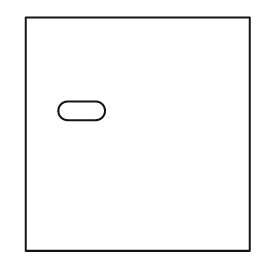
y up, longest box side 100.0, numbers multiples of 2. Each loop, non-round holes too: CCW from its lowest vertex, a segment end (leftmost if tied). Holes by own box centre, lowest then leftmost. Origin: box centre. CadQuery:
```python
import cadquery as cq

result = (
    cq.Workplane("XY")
    .moveTo(-48.0, -50.0)
    .lineTo(48.0, -50.0)
    .lineTo(48.0, 50.0)
    .lineTo(-48.0, 50.0)
    .close()
    .moveTo(-30.0, 6.0)
    .lineTo(-18.0, 6.0)
    .threePointArc((-14.0, 10.0), (-18.0, 14.0))
    .lineTo(-30.0, 14.0)
    .threePointArc((-34.0, 10.0), (-30.0, 6.0))
    .close()
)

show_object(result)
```